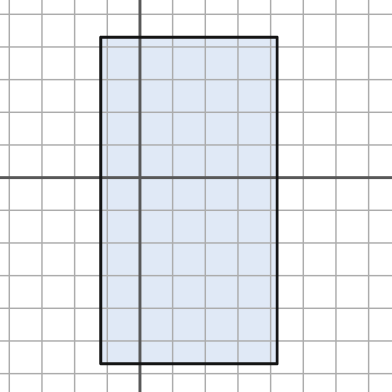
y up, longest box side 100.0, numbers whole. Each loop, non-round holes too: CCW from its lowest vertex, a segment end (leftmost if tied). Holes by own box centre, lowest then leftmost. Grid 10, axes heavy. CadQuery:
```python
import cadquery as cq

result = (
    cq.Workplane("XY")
    .moveTo(-12.0, -57.0)
    .lineTo(42.0, -57.0)
    .lineTo(42.0, 43.0)
    .lineTo(-12.0, 43.0)
    .close()
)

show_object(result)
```